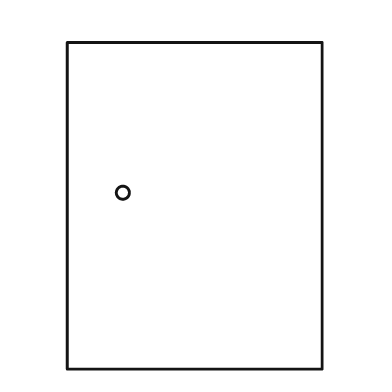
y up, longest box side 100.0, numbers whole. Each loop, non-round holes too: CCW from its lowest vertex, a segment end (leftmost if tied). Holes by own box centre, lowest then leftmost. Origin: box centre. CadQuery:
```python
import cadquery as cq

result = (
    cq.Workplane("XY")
    .moveTo(-39.0, -50.0)
    .lineTo(39.0, -50.0)
    .lineTo(39.0, 50.0)
    .lineTo(-39.0, 50.0)
    .close()
    .moveTo(-22.0, 4.0)
    .circle(2.0)
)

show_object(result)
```